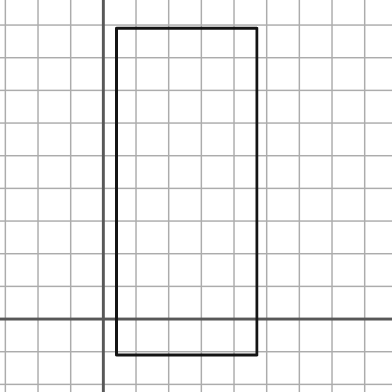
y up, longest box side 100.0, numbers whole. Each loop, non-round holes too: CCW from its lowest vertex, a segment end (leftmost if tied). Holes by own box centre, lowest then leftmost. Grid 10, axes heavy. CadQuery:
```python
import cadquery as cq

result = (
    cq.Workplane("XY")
    .moveTo(4.0, -11.0)
    .lineTo(47.0, -11.0)
    .lineTo(47.0, 89.0)
    .lineTo(4.0, 89.0)
    .close()
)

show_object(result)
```